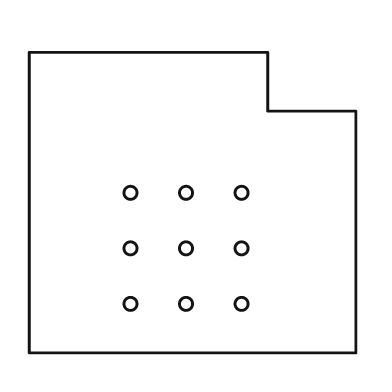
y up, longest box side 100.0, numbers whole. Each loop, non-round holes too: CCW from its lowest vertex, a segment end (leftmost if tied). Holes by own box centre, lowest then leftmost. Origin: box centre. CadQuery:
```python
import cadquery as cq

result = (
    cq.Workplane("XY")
    .moveTo(-50.0, -46.0)
    .lineTo(50.0, -46.0)
    .lineTo(50.0, 28.0)
    .lineTo(23.0, 28.0)
    .lineTo(23.0, 46.0)
    .lineTo(-50.0, 46.0)
    .close()
    .moveTo(-19.0, -31.0)
    .circle(2.0)
    .moveTo(-2.0, -31.0)
    .circle(2.0)
    .moveTo(15.0, -31.0)
    .circle(2.0)
    .moveTo(-19.0, -14.0)
    .circle(2.0)
    .moveTo(-2.0, -14.0)
    .circle(2.0)
    .moveTo(15.0, -14.0)
    .circle(2.0)
    .moveTo(-19.0, 3.0)
    .circle(2.0)
    .moveTo(-2.0, 3.0)
    .circle(2.0)
    .moveTo(15.0, 3.0)
    .circle(2.0)
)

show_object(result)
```